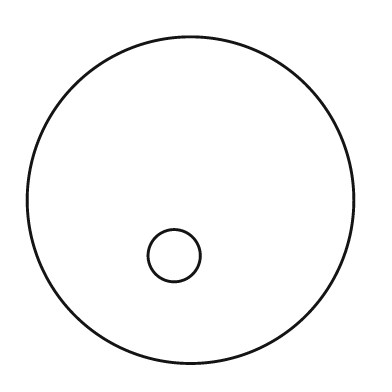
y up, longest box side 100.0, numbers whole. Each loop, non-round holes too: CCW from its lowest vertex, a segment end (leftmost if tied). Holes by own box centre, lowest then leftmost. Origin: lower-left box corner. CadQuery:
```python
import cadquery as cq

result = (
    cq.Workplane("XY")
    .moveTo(50.0, 50.0)
    .circle(50.0)
    .moveTo(45.0, 33.0)
    .circle(8.0)
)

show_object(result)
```